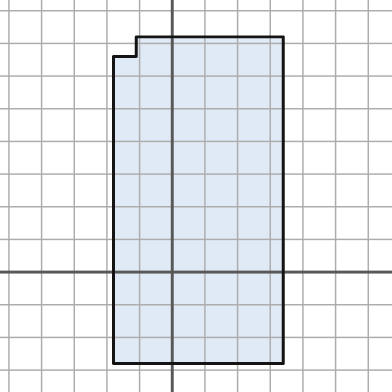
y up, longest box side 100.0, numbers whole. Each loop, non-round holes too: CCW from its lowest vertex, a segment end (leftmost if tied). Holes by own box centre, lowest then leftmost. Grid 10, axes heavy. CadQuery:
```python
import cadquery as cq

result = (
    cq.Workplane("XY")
    .moveTo(-18.0, -28.0)
    .lineTo(34.0, -28.0)
    .lineTo(34.0, 72.0)
    .lineTo(-11.0, 72.0)
    .lineTo(-11.0, 66.0)
    .lineTo(-18.0, 66.0)
    .close()
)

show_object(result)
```